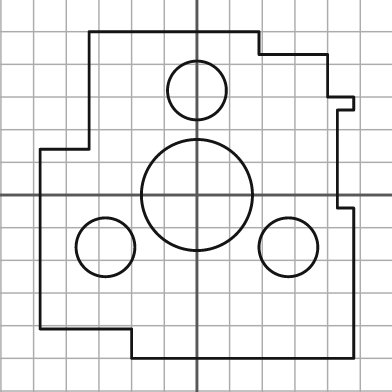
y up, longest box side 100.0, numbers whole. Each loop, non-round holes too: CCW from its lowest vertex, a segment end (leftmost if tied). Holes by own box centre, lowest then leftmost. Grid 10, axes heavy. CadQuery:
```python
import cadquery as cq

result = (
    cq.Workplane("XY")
    .moveTo(-20.0, -50.0)
    .lineTo(48.0, -50.0)
    .lineTo(48.0, -4.0)
    .lineTo(43.0, -4.0)
    .lineTo(43.0, 26.0)
    .lineTo(48.0, 26.0)
    .lineTo(48.0, 30.0)
    .lineTo(40.0, 30.0)
    .lineTo(40.0, 43.0)
    .lineTo(19.0, 43.0)
    .lineTo(19.0, 50.0)
    .lineTo(-33.0, 50.0)
    .lineTo(-33.0, 14.0)
    .lineTo(-48.0, 14.0)
    .lineTo(-48.0, -41.0)
    .lineTo(-20.0, -41.0)
    .close()
    .moveTo(-28.0, -16.0)
    .circle(9.0)
    .moveTo(28.0, -16.0)
    .circle(9.0)
    .moveTo(0.0, 0.0)
    .circle(17.0)
    .moveTo(0.0, 32.0)
    .circle(9.0)
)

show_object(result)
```